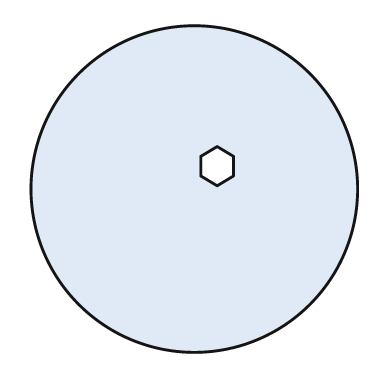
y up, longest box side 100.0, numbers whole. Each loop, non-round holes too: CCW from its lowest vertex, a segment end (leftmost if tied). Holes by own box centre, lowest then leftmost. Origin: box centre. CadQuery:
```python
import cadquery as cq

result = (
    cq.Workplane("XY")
    .moveTo(0.0, 0.0)
    .circle(50.0)
    .moveTo(7.0, 1.0)
    .lineTo(12.0, 4.0)
    .lineTo(12.0, 10.0)
    .lineTo(7.0, 13.0)
    .lineTo(2.0, 10.0)
    .lineTo(2.0, 4.0)
    .close()
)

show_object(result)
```